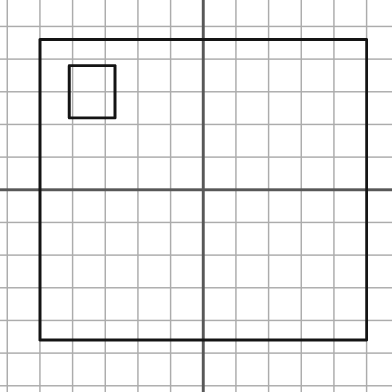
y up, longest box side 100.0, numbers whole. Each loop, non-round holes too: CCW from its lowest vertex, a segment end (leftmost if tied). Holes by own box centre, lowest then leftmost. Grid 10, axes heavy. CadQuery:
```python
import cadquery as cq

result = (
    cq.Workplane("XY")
    .moveTo(-50.0, -46.0)
    .lineTo(50.0, -46.0)
    .lineTo(50.0, 46.0)
    .lineTo(-50.0, 46.0)
    .close()
    .moveTo(-41.0, 22.0)
    .lineTo(-27.0, 22.0)
    .lineTo(-27.0, 38.0)
    .lineTo(-41.0, 38.0)
    .close()
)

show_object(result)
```